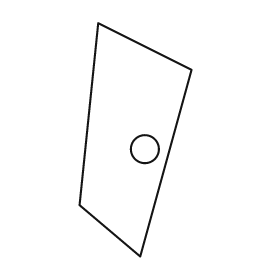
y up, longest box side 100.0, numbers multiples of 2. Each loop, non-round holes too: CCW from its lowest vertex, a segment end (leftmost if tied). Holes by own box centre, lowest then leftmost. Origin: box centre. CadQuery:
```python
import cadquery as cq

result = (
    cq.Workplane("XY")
    .moveTo(2.0, -50.0)
    .lineTo(24.0, 30.0)
    .lineTo(-16.0, 50.0)
    .lineTo(-24.0, -28.0)
    .close()
    .moveTo(4.0, -4.0)
    .circle(6.0)
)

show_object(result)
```